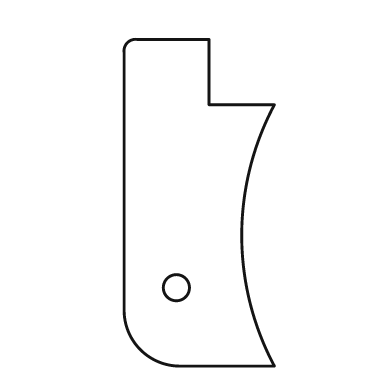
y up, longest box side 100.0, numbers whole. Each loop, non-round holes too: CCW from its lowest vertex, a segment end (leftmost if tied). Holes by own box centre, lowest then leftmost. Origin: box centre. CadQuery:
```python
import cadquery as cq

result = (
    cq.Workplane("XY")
    .moveTo(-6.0, -50.0)
    .lineTo(23.0, -50.0)
    .threePointArc((13.0, -10.0), (23.0, 30.0))
    .lineTo(3.0, 30.0)
    .lineTo(3.0, 50.0)
    .lineTo(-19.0, 50.0)
    .threePointArc((-22.0, 49.0), (-23.0, 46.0))
    .lineTo(-23.0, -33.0)
    .threePointArc((-18.0, -45.0), (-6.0, -50.0))
    .close()
    .moveTo(-7.0, -26.0)
    .circle(4.0)
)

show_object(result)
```